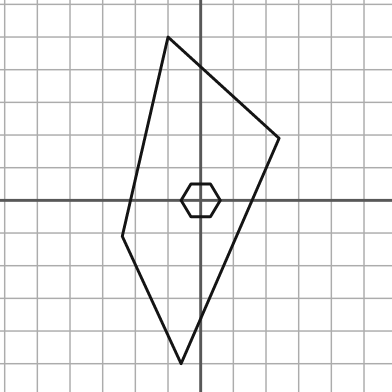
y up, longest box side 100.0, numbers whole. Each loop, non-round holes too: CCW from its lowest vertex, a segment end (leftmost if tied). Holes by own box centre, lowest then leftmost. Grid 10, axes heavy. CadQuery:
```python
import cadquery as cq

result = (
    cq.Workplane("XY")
    .moveTo(-6.0, -50.0)
    .lineTo(24.0, 19.0)
    .lineTo(-10.0, 50.0)
    .lineTo(-24.0, -11.0)
    .close()
    .moveTo(-3.0, -5.0)
    .lineTo(3.0, -5.0)
    .lineTo(6.0, 0.0)
    .lineTo(3.0, 5.0)
    .lineTo(-3.0, 5.0)
    .lineTo(-6.0, 0.0)
    .close()
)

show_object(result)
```